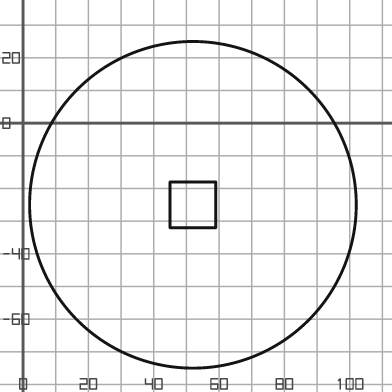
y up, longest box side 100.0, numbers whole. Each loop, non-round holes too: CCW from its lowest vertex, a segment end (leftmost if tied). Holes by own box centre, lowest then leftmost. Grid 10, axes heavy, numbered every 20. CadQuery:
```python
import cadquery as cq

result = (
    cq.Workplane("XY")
    .moveTo(52.0, -25.0)
    .circle(50.0)
    .moveTo(45.0, -32.0)
    .lineTo(59.0, -32.0)
    .lineTo(59.0, -18.0)
    .lineTo(45.0, -18.0)
    .close()
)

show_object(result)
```